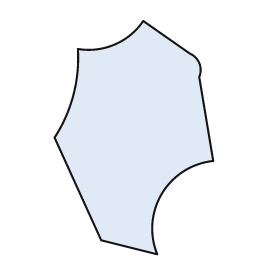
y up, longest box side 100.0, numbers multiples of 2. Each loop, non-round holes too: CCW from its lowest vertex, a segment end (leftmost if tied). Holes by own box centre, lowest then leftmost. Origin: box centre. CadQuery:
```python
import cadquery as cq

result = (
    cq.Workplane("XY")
    .moveTo(10.0, -50.0)
    .threePointArc((12.0, -24.0), (34.0, -10.0))
    .lineTo(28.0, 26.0)
    .threePointArc((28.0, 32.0), (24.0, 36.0))
    .lineTo(4.0, 50.0)
    .threePointArc((-8.0, 40.0), (-24.0, 38.0))
    .threePointArc((-26.0, 18.0), (-34.0, 0.0))
    .lineTo(-14.0, -44.0)
    .close()
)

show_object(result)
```